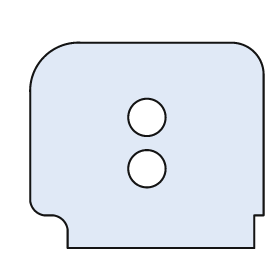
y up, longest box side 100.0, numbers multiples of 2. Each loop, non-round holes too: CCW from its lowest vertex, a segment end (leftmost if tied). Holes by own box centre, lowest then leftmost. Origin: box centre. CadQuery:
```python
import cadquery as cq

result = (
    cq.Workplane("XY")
    .moveTo(-34.0, -44.0)
    .lineTo(46.0, -44.0)
    .lineTo(46.0, -30.0)
    .lineTo(50.0, -30.0)
    .lineTo(50.0, 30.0)
    .threePointArc((46.0, 40.0), (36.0, 44.0))
    .lineTo(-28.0, 44.0)
    .threePointArc((-44.0, 38.0), (-50.0, 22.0))
    .lineTo(-50.0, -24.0)
    .threePointArc((-48.0, -28.0), (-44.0, -30.0))
    .lineTo(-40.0, -30.0)
    .threePointArc((-36.0, -32.0), (-34.0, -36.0))
    .close()
    .moveTo(0.0, -10.0)
    .circle(8.0)
    .moveTo(0.0, 12.0)
    .circle(8.0)
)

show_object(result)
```